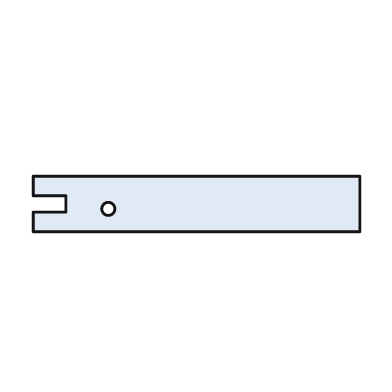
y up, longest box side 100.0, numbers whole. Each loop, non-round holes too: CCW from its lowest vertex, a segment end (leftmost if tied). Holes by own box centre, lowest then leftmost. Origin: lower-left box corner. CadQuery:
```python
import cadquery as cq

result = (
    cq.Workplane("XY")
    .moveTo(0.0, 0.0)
    .lineTo(100.0, 0.0)
    .lineTo(100.0, 17.0)
    .lineTo(0.0, 17.0)
    .lineTo(0.0, 11.0)
    .lineTo(10.0, 11.0)
    .lineTo(10.0, 6.0)
    .lineTo(0.0, 6.0)
    .close()
    .moveTo(23.0, 7.0)
    .circle(2.0)
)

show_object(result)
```